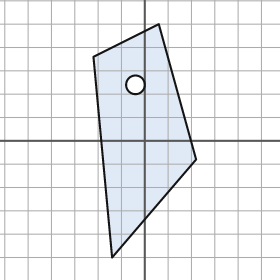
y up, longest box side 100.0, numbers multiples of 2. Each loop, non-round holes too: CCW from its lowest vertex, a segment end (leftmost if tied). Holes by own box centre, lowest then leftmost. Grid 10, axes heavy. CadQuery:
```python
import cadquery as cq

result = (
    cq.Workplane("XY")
    .moveTo(-14.0, -50.0)
    .lineTo(22.0, -8.0)
    .lineTo(6.0, 50.0)
    .lineTo(-22.0, 36.0)
    .close()
    .moveTo(-4.0, 24.0)
    .circle(4.0)
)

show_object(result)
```